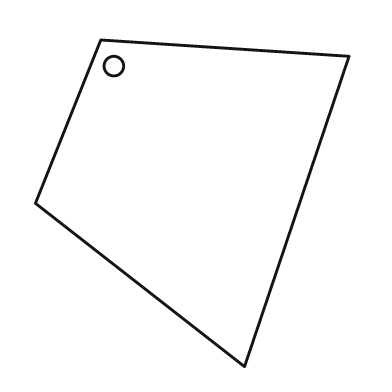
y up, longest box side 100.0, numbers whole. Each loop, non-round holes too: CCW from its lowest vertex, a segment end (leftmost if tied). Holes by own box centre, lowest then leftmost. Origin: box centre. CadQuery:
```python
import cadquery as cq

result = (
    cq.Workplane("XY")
    .moveTo(16.0, -50.0)
    .lineTo(48.0, 45.0)
    .lineTo(-28.0, 50.0)
    .lineTo(-48.0, 0.0)
    .close()
    .moveTo(-24.0, 42.0)
    .circle(3.0)
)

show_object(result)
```